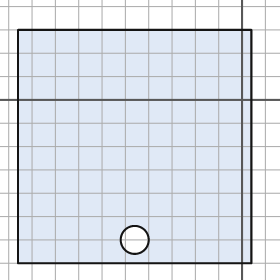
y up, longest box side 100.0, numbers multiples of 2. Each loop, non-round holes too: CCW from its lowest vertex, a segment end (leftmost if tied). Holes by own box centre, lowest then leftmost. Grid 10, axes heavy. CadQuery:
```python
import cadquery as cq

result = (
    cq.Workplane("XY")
    .moveTo(-96.0, -70.0)
    .lineTo(4.0, -70.0)
    .lineTo(4.0, 30.0)
    .lineTo(-96.0, 30.0)
    .close()
    .moveTo(-46.0, -60.0)
    .circle(6.0)
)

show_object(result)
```